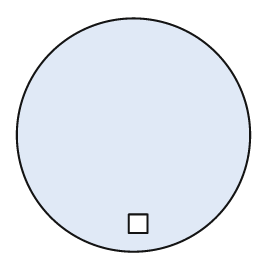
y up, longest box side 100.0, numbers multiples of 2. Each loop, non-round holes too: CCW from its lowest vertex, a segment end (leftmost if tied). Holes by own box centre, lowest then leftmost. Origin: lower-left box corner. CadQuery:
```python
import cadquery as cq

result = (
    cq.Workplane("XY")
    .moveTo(50.0, 50.0)
    .circle(50.0)
    .moveTo(48.0, 8.0)
    .lineTo(56.0, 8.0)
    .lineTo(56.0, 16.0)
    .lineTo(48.0, 16.0)
    .close()
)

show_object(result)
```